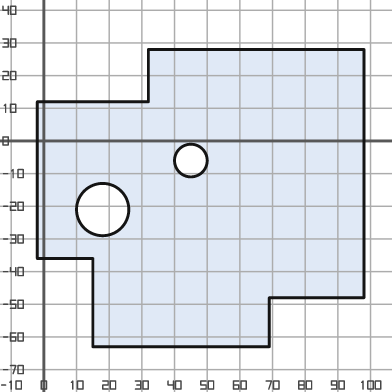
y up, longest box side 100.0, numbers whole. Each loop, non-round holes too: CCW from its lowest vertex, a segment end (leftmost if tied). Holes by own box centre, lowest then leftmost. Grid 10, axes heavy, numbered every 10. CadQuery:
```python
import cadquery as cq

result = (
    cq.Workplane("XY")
    .moveTo(15.0, -63.0)
    .lineTo(69.0, -63.0)
    .lineTo(69.0, -48.0)
    .lineTo(98.0, -48.0)
    .lineTo(98.0, 28.0)
    .lineTo(32.0, 28.0)
    .lineTo(32.0, 12.0)
    .lineTo(-2.0, 12.0)
    .lineTo(-2.0, -36.0)
    .lineTo(15.0, -36.0)
    .close()
    .moveTo(18.0, -21.0)
    .circle(8.0)
    .moveTo(45.0, -6.0)
    .circle(5.0)
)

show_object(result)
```